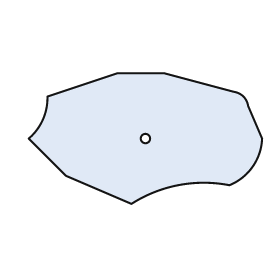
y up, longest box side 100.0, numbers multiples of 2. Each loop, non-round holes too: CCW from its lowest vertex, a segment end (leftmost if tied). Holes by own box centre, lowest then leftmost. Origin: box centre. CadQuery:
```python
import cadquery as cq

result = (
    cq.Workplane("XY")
    .moveTo(-6.0, -28.0)
    .threePointArc((14.0, -20.0), (36.0, -20.0))
    .threePointArc((46.0, -12.0), (50.0, 0.0))
    .lineTo(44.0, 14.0)
    .threePointArc((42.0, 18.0), (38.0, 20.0))
    .lineTo(8.0, 28.0)
    .lineTo(-12.0, 28.0)
    .lineTo(-42.0, 18.0)
    .threePointArc((-44.0, 8.0), (-50.0, 0.0))
    .lineTo(-34.0, -16.0)
    .close()
    .moveTo(0.0, 0.0)
    .circle(2.0)
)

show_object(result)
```